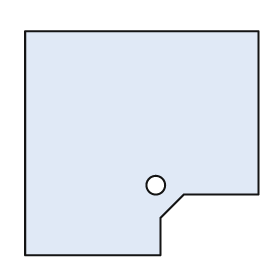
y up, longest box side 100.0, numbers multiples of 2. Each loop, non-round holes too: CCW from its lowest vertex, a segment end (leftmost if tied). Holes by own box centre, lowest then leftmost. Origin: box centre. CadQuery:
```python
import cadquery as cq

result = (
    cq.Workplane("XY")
    .moveTo(-50.0, -48.0)
    .lineTo(8.0, -48.0)
    .lineTo(8.0, -32.0)
    .lineTo(18.0, -22.0)
    .lineTo(50.0, -22.0)
    .lineTo(50.0, 48.0)
    .lineTo(-50.0, 48.0)
    .close()
    .moveTo(6.0, -18.0)
    .circle(4.0)
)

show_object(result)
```